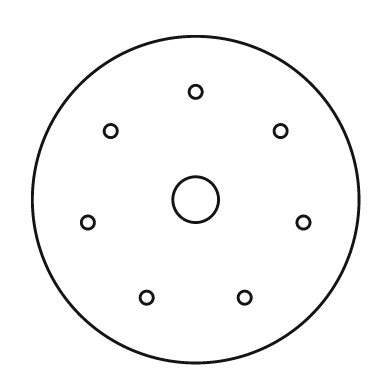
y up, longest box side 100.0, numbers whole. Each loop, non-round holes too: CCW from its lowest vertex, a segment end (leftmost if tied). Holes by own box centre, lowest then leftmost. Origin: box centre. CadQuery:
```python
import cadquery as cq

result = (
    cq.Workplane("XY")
    .moveTo(0.0, 0.0)
    .circle(50.0)
    .moveTo(-15.0, -30.0)
    .circle(2.0)
    .moveTo(15.0, -30.0)
    .circle(2.0)
    .moveTo(-33.0, -7.0)
    .circle(2.0)
    .moveTo(33.0, -7.0)
    .circle(2.0)
    .moveTo(0.0, 0.0)
    .circle(7.0)
    .moveTo(-26.0, 21.0)
    .circle(2.0)
    .moveTo(26.0, 21.0)
    .circle(2.0)
    .moveTo(0.0, 33.0)
    .circle(2.0)
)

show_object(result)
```